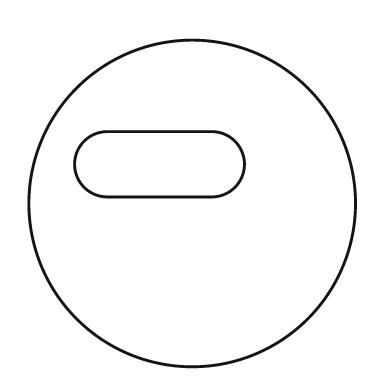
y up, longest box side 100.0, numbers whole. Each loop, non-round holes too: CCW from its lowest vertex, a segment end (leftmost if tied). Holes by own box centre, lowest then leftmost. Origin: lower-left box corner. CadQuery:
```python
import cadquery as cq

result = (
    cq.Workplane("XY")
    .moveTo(50.0, 50.0)
    .circle(50.0)
    .moveTo(24.0, 52.0)
    .lineTo(56.0, 52.0)
    .threePointArc((66.0, 62.0), (56.0, 72.0))
    .lineTo(24.0, 72.0)
    .threePointArc((14.0, 62.0), (24.0, 52.0))
    .close()
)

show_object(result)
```